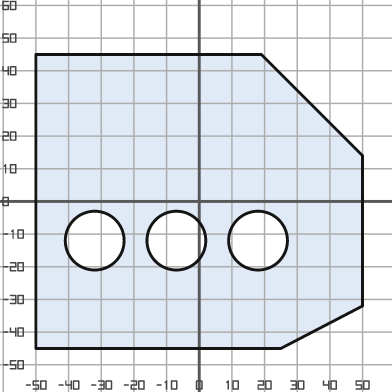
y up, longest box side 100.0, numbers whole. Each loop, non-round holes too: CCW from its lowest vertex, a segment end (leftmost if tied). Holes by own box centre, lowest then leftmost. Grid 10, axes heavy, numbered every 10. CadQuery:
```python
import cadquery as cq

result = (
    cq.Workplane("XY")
    .moveTo(-50.0, -45.0)
    .lineTo(25.0, -45.0)
    .lineTo(50.0, -32.0)
    .lineTo(50.0, 14.0)
    .lineTo(19.0, 45.0)
    .lineTo(-50.0, 45.0)
    .close()
    .moveTo(-32.0, -12.0)
    .circle(9.0)
    .moveTo(-7.0, -12.0)
    .circle(9.0)
    .moveTo(18.0, -12.0)
    .circle(9.0)
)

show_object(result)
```